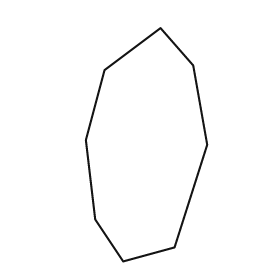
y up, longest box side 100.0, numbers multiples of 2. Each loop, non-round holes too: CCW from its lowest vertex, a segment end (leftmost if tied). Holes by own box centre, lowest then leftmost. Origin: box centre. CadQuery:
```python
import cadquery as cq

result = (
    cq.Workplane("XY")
    .moveTo(-10.0, -50.0)
    .lineTo(12.0, -44.0)
    .lineTo(26.0, 0.0)
    .lineTo(20.0, 34.0)
    .lineTo(6.0, 50.0)
    .lineTo(-18.0, 32.0)
    .lineTo(-26.0, 2.0)
    .lineTo(-22.0, -32.0)
    .close()
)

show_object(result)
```